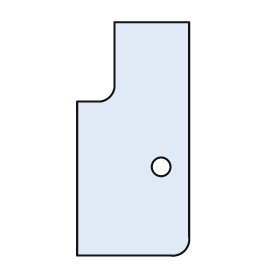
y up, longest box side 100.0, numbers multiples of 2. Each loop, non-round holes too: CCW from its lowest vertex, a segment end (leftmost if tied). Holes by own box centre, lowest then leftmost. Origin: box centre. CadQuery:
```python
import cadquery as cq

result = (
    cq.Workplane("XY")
    .moveTo(-24.0, -50.0)
    .lineTo(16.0, -50.0)
    .threePointArc((22.0, -48.0), (24.0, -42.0))
    .lineTo(24.0, 50.0)
    .lineTo(-8.0, 50.0)
    .lineTo(-8.0, 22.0)
    .threePointArc((-10.0, 18.0), (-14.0, 16.0))
    .lineTo(-24.0, 16.0)
    .close()
    .moveTo(12.0, -12.0)
    .circle(4.0)
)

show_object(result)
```